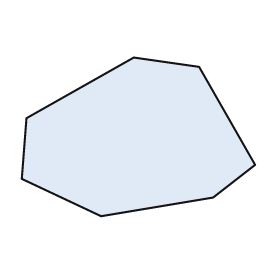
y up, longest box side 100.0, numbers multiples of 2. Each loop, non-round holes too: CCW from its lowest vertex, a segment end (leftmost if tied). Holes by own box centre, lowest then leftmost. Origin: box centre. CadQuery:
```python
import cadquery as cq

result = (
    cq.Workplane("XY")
    .moveTo(-16.0, -34.0)
    .lineTo(32.0, -26.0)
    .lineTo(50.0, -12.0)
    .lineTo(26.0, 30.0)
    .lineTo(-2.0, 34.0)
    .lineTo(-48.0, 8.0)
    .lineTo(-50.0, -18.0)
    .close()
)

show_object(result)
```